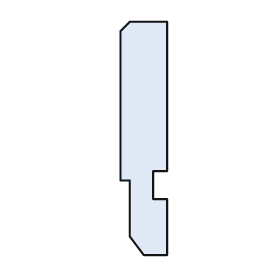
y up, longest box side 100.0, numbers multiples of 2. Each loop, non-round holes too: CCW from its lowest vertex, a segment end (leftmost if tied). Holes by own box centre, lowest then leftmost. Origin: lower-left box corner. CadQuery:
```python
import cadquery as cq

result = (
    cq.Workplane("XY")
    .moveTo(10.0, 0.0)
    .lineTo(20.0, 0.0)
    .lineTo(20.0, 24.0)
    .lineTo(14.0, 24.0)
    .lineTo(14.0, 36.0)
    .lineTo(20.0, 36.0)
    .lineTo(20.0, 100.0)
    .lineTo(4.0, 100.0)
    .lineTo(0.0, 96.0)
    .lineTo(0.0, 32.0)
    .lineTo(4.0, 32.0)
    .lineTo(4.0, 8.0)
    .close()
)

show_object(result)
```